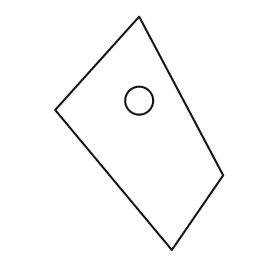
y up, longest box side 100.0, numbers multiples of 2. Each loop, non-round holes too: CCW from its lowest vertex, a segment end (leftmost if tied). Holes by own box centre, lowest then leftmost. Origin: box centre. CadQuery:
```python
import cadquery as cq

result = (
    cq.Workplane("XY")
    .moveTo(14.0, -50.0)
    .lineTo(36.0, -18.0)
    .lineTo(0.0, 50.0)
    .lineTo(-36.0, 10.0)
    .close()
    .moveTo(0.0, 14.0)
    .circle(6.0)
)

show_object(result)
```